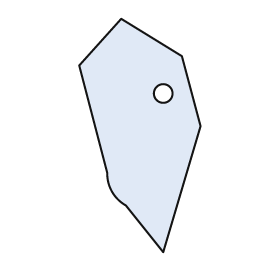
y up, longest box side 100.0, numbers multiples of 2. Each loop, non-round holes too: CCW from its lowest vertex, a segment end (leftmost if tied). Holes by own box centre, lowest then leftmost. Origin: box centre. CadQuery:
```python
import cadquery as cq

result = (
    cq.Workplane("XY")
    .moveTo(10.0, -50.0)
    .lineTo(26.0, 4.0)
    .lineTo(18.0, 34.0)
    .lineTo(-8.0, 50.0)
    .lineTo(-26.0, 30.0)
    .lineTo(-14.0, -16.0)
    .threePointArc((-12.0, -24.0), (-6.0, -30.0))
    .close()
    .moveTo(10.0, 18.0)
    .circle(4.0)
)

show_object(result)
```